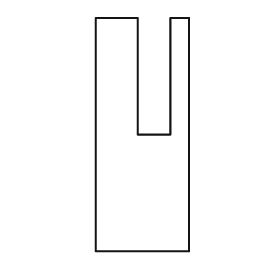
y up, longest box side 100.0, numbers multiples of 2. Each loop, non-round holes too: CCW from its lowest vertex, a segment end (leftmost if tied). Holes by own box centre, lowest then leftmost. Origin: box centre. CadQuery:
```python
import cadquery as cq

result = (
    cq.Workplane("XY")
    .moveTo(-20.0, -50.0)
    .lineTo(20.0, -50.0)
    .lineTo(20.0, 50.0)
    .lineTo(12.0, 50.0)
    .lineTo(12.0, 0.0)
    .lineTo(-2.0, 0.0)
    .lineTo(-2.0, 50.0)
    .lineTo(-20.0, 50.0)
    .close()
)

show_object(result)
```